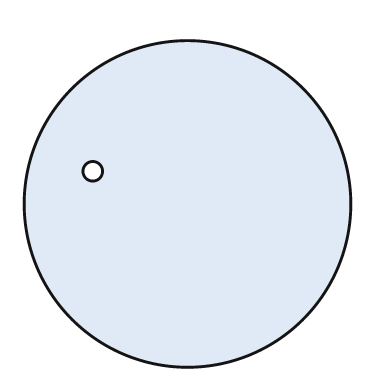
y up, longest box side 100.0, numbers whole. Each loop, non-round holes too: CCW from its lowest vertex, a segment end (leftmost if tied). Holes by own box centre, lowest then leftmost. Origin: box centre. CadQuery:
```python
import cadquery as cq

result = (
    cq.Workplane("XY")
    .moveTo(0.0, 0.0)
    .circle(50.0)
    .moveTo(-29.0, 10.0)
    .circle(3.0)
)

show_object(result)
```